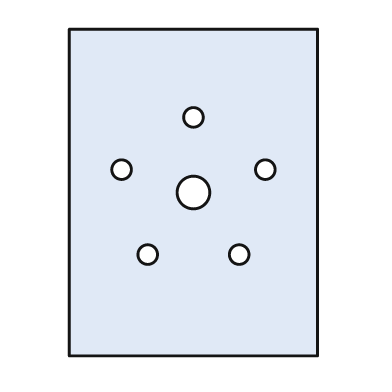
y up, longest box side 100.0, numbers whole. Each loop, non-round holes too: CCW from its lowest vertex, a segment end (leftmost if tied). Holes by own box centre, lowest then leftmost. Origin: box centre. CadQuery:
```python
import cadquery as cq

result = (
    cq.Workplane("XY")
    .moveTo(-38.0, -50.0)
    .lineTo(38.0, -50.0)
    .lineTo(38.0, 50.0)
    .lineTo(-38.0, 50.0)
    .close()
    .moveTo(-14.0, -19.0)
    .circle(3.0)
    .moveTo(14.0, -19.0)
    .circle(3.0)
    .moveTo(0.0, 0.0)
    .circle(5.0)
    .moveTo(-22.0, 7.0)
    .circle(3.0)
    .moveTo(22.0, 7.0)
    .circle(3.0)
    .moveTo(0.0, 23.0)
    .circle(3.0)
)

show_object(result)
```